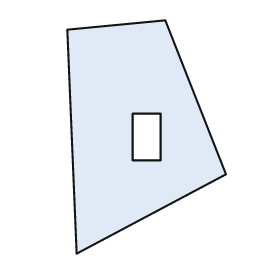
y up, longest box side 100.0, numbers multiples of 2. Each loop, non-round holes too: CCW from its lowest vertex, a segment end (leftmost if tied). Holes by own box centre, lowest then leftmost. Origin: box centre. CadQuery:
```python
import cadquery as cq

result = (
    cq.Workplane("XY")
    .moveTo(-30.0, -50.0)
    .lineTo(34.0, -16.0)
    .lineTo(8.0, 50.0)
    .lineTo(-34.0, 46.0)
    .close()
    .moveTo(-6.0, -10.0)
    .lineTo(6.0, -10.0)
    .lineTo(6.0, 10.0)
    .lineTo(-6.0, 10.0)
    .close()
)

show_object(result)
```